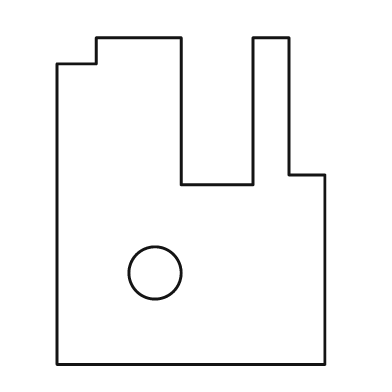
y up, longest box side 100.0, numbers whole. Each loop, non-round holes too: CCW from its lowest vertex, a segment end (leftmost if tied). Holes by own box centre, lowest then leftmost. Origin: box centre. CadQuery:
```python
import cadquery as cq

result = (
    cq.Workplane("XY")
    .moveTo(-41.0, -50.0)
    .lineTo(41.0, -50.0)
    .lineTo(41.0, 8.0)
    .lineTo(30.0, 8.0)
    .lineTo(30.0, 50.0)
    .lineTo(19.0, 50.0)
    .lineTo(19.0, 5.0)
    .lineTo(-3.0, 5.0)
    .lineTo(-3.0, 50.0)
    .lineTo(-29.0, 50.0)
    .lineTo(-29.0, 42.0)
    .lineTo(-41.0, 42.0)
    .close()
    .moveTo(-11.0, -22.0)
    .circle(8.0)
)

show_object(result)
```